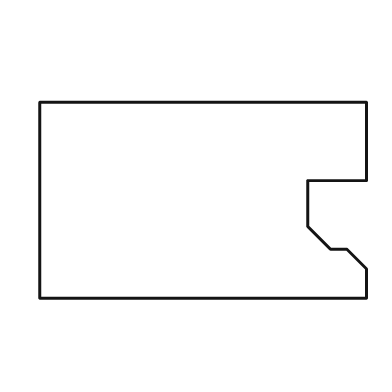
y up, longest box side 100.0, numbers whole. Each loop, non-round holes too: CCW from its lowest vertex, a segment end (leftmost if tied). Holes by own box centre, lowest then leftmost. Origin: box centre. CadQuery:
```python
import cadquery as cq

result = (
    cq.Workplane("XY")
    .moveTo(-50.0, -30.0)
    .lineTo(50.0, -30.0)
    .lineTo(50.0, -21.0)
    .lineTo(44.0, -15.0)
    .lineTo(39.0, -15.0)
    .lineTo(32.0, -8.0)
    .lineTo(32.0, 6.0)
    .lineTo(50.0, 6.0)
    .lineTo(50.0, 30.0)
    .lineTo(-50.0, 30.0)
    .close()
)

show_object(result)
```